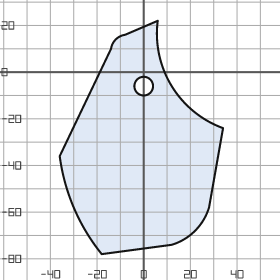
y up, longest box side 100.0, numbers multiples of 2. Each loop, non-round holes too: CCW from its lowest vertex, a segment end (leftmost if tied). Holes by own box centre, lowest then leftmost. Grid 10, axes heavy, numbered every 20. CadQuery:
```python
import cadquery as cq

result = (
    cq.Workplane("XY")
    .moveTo(-18.0, -78.0)
    .lineTo(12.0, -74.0)
    .threePointArc((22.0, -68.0), (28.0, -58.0))
    .lineTo(34.0, -24.0)
    .threePointArc((12.0, -6.0), (6.0, 22.0))
    .lineTo(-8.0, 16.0)
    .threePointArc((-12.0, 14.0), (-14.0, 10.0))
    .lineTo(-36.0, -36.0)
    .threePointArc((-30.0, -58.0), (-18.0, -78.0))
    .close()
    .moveTo(0.0, -6.0)
    .circle(4.0)
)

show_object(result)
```